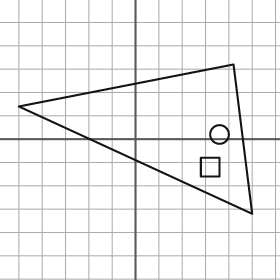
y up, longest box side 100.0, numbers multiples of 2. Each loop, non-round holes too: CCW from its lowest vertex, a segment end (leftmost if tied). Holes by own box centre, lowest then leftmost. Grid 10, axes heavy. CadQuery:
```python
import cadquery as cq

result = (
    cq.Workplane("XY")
    .moveTo(50.0, -32.0)
    .lineTo(42.0, 32.0)
    .lineTo(-50.0, 14.0)
    .close()
    .moveTo(28.0, -16.0)
    .lineTo(36.0, -16.0)
    .lineTo(36.0, -8.0)
    .lineTo(28.0, -8.0)
    .close()
    .moveTo(36.0, 2.0)
    .circle(4.0)
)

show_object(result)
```